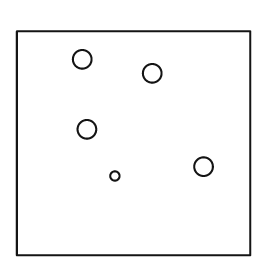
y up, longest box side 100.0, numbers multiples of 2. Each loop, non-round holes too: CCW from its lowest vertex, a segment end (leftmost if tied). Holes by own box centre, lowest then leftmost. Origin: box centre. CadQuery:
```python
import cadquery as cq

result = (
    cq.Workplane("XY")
    .moveTo(-50.0, -48.0)
    .lineTo(50.0, -48.0)
    .lineTo(50.0, 48.0)
    .lineTo(-50.0, 48.0)
    .close()
    .moveTo(-8.0, -14.0)
    .circle(2.0)
    .moveTo(30.0, -10.0)
    .circle(4.0)
    .moveTo(-20.0, 6.0)
    .circle(4.0)
    .moveTo(8.0, 30.0)
    .circle(4.0)
    .moveTo(-22.0, 36.0)
    .circle(4.0)
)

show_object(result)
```